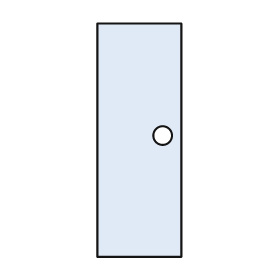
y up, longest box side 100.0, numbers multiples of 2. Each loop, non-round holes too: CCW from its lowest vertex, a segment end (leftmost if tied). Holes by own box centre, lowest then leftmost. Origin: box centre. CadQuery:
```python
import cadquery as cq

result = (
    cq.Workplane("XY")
    .moveTo(-18.0, -50.0)
    .lineTo(18.0, -50.0)
    .lineTo(18.0, 50.0)
    .lineTo(-18.0, 50.0)
    .close()
    .moveTo(10.0, 2.0)
    .circle(4.0)
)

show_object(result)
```